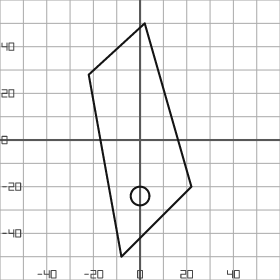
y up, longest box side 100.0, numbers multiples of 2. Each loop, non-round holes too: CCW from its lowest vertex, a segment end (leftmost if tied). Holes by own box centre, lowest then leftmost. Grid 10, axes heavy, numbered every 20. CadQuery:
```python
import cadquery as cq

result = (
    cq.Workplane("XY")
    .moveTo(-8.0, -50.0)
    .lineTo(22.0, -20.0)
    .lineTo(2.0, 50.0)
    .lineTo(-22.0, 28.0)
    .close()
    .moveTo(0.0, -24.0)
    .circle(4.0)
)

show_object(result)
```